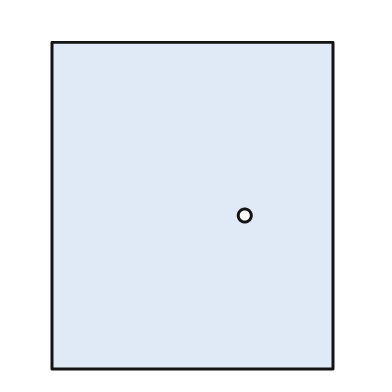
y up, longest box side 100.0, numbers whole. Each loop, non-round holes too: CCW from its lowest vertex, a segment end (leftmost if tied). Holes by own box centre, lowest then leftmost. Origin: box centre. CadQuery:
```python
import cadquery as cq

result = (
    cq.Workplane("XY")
    .moveTo(-43.0, -50.0)
    .lineTo(43.0, -50.0)
    .lineTo(43.0, 50.0)
    .lineTo(-43.0, 50.0)
    .close()
    .moveTo(16.0, -3.0)
    .circle(2.0)
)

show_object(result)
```